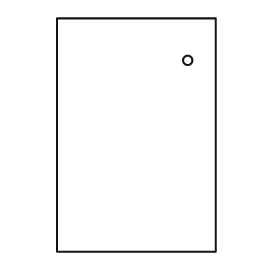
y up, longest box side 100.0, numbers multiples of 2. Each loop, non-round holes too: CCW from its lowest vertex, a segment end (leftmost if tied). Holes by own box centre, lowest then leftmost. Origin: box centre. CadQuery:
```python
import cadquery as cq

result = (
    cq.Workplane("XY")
    .moveTo(-34.0, -50.0)
    .lineTo(34.0, -50.0)
    .lineTo(34.0, 50.0)
    .lineTo(-34.0, 50.0)
    .close()
    .moveTo(22.0, 32.0)
    .circle(2.0)
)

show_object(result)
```